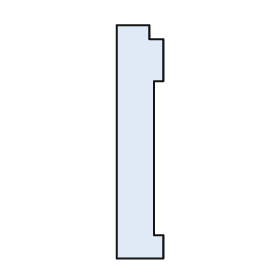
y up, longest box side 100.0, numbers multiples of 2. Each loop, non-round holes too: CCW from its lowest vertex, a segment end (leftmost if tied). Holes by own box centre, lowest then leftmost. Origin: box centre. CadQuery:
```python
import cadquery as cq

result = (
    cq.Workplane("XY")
    .moveTo(-10.0, -50.0)
    .lineTo(10.0, -50.0)
    .lineTo(10.0, -40.0)
    .lineTo(6.0, -40.0)
    .lineTo(6.0, 26.0)
    .lineTo(10.0, 26.0)
    .lineTo(10.0, 44.0)
    .lineTo(4.0, 44.0)
    .lineTo(4.0, 50.0)
    .lineTo(-10.0, 50.0)
    .close()
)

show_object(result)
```